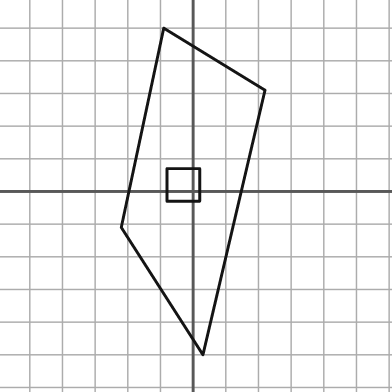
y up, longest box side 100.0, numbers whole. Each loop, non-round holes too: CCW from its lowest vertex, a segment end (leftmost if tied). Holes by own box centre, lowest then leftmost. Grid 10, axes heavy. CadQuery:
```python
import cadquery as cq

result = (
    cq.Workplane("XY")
    .moveTo(3.0, -50.0)
    .lineTo(22.0, 31.0)
    .lineTo(-9.0, 50.0)
    .lineTo(-22.0, -11.0)
    .close()
    .moveTo(-8.0, -3.0)
    .lineTo(2.0, -3.0)
    .lineTo(2.0, 7.0)
    .lineTo(-8.0, 7.0)
    .close()
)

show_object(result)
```